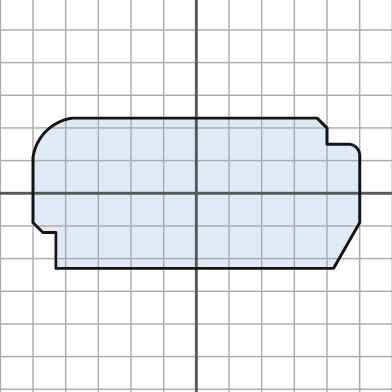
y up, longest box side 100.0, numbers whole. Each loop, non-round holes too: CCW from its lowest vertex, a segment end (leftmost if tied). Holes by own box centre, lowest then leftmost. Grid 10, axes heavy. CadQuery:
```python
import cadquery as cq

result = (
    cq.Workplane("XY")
    .moveTo(-43.0, -23.0)
    .lineTo(42.0, -23.0)
    .lineTo(50.0, -9.0)
    .lineTo(50.0, 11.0)
    .threePointArc((49.0, 14.0), (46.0, 15.0))
    .lineTo(40.0, 15.0)
    .lineTo(40.0, 20.0)
    .lineTo(37.0, 23.0)
    .lineTo(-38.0, 23.0)
    .threePointArc((-46.0, 19.0), (-50.0, 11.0))
    .lineTo(-50.0, -9.0)
    .lineTo(-47.0, -12.0)
    .lineTo(-43.0, -12.0)
    .close()
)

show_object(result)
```